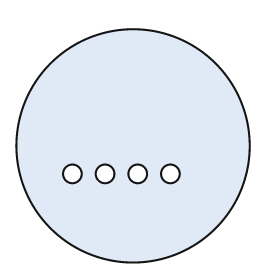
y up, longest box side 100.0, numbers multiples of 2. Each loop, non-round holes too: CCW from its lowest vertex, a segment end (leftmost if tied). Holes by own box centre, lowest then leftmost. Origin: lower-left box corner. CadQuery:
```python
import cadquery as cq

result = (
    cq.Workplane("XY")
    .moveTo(50.0, 50.0)
    .circle(50.0)
    .moveTo(24.0, 38.0)
    .circle(4.0)
    .moveTo(38.0, 38.0)
    .circle(4.0)
    .moveTo(52.0, 38.0)
    .circle(4.0)
    .moveTo(66.0, 38.0)
    .circle(4.0)
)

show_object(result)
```